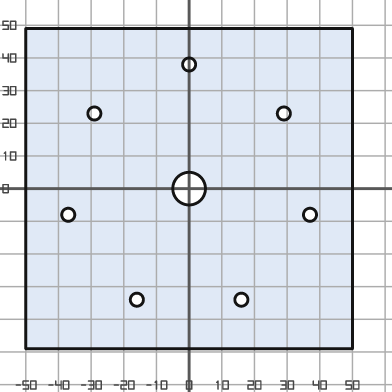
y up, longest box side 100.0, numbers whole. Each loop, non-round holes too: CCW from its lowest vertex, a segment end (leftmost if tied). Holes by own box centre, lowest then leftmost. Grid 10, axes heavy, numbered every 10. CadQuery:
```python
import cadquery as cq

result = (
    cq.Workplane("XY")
    .moveTo(-50.0, -49.0)
    .lineTo(50.0, -49.0)
    .lineTo(50.0, 49.0)
    .lineTo(-50.0, 49.0)
    .close()
    .moveTo(-16.0, -34.0)
    .circle(2.0)
    .moveTo(16.0, -34.0)
    .circle(2.0)
    .moveTo(-37.0, -8.0)
    .circle(2.0)
    .moveTo(37.0, -8.0)
    .circle(2.0)
    .moveTo(0.0, 0.0)
    .circle(5.0)
    .moveTo(-29.0, 23.0)
    .circle(2.0)
    .moveTo(29.0, 23.0)
    .circle(2.0)
    .moveTo(0.0, 38.0)
    .circle(2.0)
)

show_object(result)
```